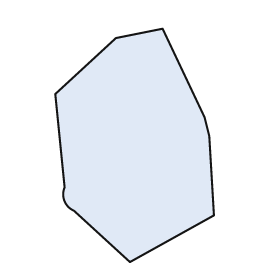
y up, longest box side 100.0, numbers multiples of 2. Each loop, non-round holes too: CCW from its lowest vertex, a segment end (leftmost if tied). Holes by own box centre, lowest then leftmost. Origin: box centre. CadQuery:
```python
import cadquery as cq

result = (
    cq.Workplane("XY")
    .moveTo(-2.0, -50.0)
    .lineTo(34.0, -30.0)
    .lineTo(32.0, 4.0)
    .lineTo(30.0, 12.0)
    .lineTo(12.0, 50.0)
    .lineTo(-8.0, 46.0)
    .lineTo(-34.0, 22.0)
    .lineTo(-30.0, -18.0)
    .threePointArc((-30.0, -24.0), (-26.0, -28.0))
    .close()
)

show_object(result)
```